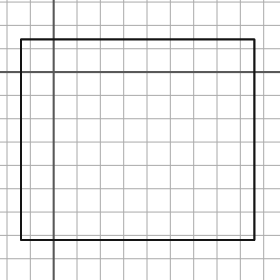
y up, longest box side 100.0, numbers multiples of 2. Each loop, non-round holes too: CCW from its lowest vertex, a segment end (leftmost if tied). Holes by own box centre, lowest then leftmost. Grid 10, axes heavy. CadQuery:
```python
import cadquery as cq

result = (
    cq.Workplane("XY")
    .moveTo(-14.0, -72.0)
    .lineTo(86.0, -72.0)
    .lineTo(86.0, 14.0)
    .lineTo(-14.0, 14.0)
    .close()
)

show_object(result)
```